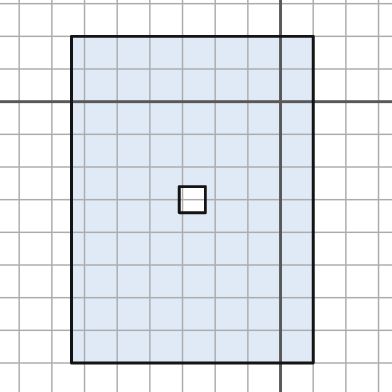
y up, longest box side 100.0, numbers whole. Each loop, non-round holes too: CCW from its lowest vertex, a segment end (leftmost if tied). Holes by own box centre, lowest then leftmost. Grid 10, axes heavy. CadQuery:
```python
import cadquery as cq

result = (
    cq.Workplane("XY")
    .moveTo(-64.0, -80.0)
    .lineTo(10.0, -80.0)
    .lineTo(10.0, 20.0)
    .lineTo(-64.0, 20.0)
    .close()
    .moveTo(-31.0, -34.0)
    .lineTo(-23.0, -34.0)
    .lineTo(-23.0, -26.0)
    .lineTo(-31.0, -26.0)
    .close()
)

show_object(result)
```